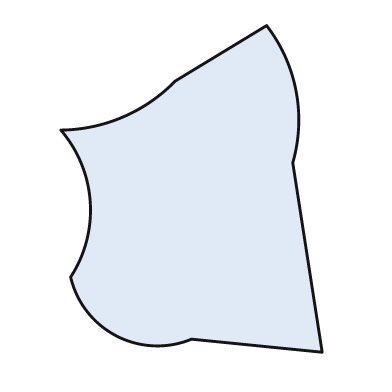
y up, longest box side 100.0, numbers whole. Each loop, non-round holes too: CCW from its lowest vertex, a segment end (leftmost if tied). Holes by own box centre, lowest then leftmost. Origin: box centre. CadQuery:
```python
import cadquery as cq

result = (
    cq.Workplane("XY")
    .moveTo(40.0, -50.0)
    .lineTo(31.0, 8.0)
    .threePointArc((32.0, 30.0), (23.0, 50.0))
    .lineTo(-5.0, 33.0)
    .threePointArc((-21.0, 22.0), (-40.0, 18.0))
    .threePointArc((-31.0, -4.0), (-37.0, -27.0))
    .threePointArc((-23.0, -45.0), (0.0, -46.0))
    .close()
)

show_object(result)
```